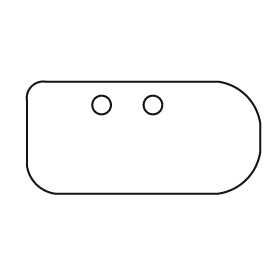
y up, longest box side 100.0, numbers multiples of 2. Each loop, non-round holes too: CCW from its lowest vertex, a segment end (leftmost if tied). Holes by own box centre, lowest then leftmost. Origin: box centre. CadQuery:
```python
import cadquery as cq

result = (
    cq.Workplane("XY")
    .moveTo(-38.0, -24.0)
    .lineTo(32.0, -24.0)
    .threePointArc((44.0, -18.0), (50.0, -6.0))
    .lineTo(50.0, 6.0)
    .threePointArc((44.0, 18.0), (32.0, 24.0))
    .lineTo(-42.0, 24.0)
    .threePointArc((-48.0, 22.0), (-50.0, 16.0))
    .lineTo(-50.0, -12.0)
    .threePointArc((-46.0, -20.0), (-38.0, -24.0))
    .close()
    .moveTo(-18.0, 14.0)
    .circle(4.0)
    .moveTo(4.0, 14.0)
    .circle(4.0)
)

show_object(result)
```